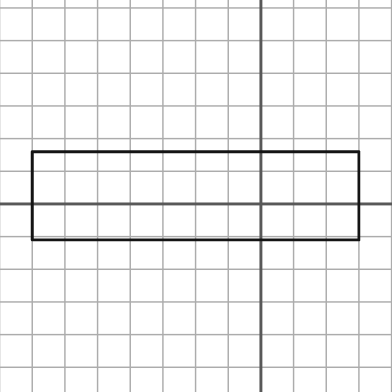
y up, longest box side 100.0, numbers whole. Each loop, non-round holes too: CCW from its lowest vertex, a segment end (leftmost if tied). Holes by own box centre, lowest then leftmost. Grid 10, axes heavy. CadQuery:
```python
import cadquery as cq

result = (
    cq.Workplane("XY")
    .moveTo(-70.0, -11.0)
    .lineTo(30.0, -11.0)
    .lineTo(30.0, 16.0)
    .lineTo(-70.0, 16.0)
    .close()
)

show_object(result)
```